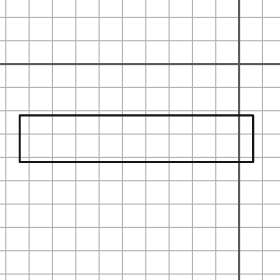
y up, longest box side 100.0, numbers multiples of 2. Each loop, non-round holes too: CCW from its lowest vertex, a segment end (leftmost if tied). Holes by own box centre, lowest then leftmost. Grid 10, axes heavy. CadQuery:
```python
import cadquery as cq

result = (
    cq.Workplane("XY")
    .moveTo(-94.0, -42.0)
    .lineTo(6.0, -42.0)
    .lineTo(6.0, -22.0)
    .lineTo(-94.0, -22.0)
    .close()
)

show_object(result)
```